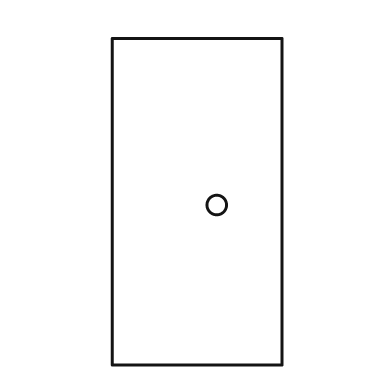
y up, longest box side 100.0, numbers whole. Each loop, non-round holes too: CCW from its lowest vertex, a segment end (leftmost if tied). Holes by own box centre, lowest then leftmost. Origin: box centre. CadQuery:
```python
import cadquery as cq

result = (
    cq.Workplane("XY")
    .moveTo(-26.0, -50.0)
    .lineTo(26.0, -50.0)
    .lineTo(26.0, 50.0)
    .lineTo(-26.0, 50.0)
    .close()
    .moveTo(6.0, -1.0)
    .circle(3.0)
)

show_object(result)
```